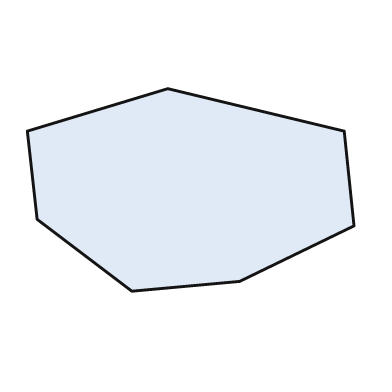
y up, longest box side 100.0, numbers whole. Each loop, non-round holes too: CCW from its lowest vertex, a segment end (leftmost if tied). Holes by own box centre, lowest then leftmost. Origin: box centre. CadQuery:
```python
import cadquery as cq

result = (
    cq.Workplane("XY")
    .moveTo(-18.0, -31.0)
    .lineTo(15.0, -28.0)
    .lineTo(50.0, -11.0)
    .lineTo(47.0, 18.0)
    .lineTo(-7.0, 31.0)
    .lineTo(-50.0, 18.0)
    .lineTo(-47.0, -9.0)
    .close()
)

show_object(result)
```